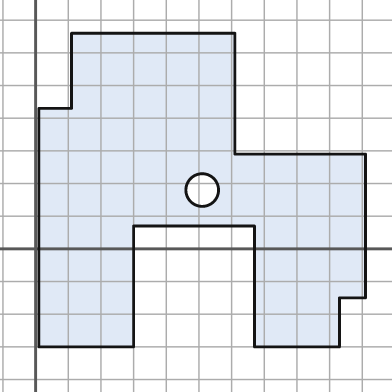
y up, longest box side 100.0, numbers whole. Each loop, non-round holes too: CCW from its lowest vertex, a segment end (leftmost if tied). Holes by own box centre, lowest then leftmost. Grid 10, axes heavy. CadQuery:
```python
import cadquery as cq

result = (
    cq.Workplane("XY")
    .moveTo(1.0, -30.0)
    .lineTo(30.0, -30.0)
    .lineTo(30.0, 7.0)
    .lineTo(67.0, 7.0)
    .lineTo(67.0, -30.0)
    .lineTo(93.0, -30.0)
    .lineTo(93.0, -15.0)
    .lineTo(101.0, -15.0)
    .lineTo(101.0, 29.0)
    .lineTo(61.0, 29.0)
    .lineTo(61.0, 66.0)
    .lineTo(11.0, 66.0)
    .lineTo(11.0, 43.0)
    .lineTo(1.0, 43.0)
    .close()
    .moveTo(51.0, 18.0)
    .circle(5.0)
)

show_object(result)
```